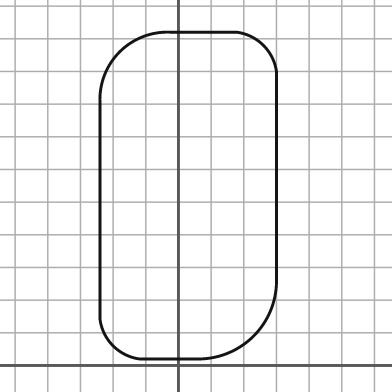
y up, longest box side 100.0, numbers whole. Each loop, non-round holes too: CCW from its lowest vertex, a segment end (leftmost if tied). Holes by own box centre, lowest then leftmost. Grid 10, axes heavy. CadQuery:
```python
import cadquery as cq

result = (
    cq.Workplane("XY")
    .moveTo(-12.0, 2.0)
    .lineTo(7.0, 2.0)
    .threePointArc((23.0, 9.0), (30.0, 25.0))
    .lineTo(30.0, 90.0)
    .threePointArc((26.0, 98.0), (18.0, 102.0))
    .lineTo(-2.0, 102.0)
    .threePointArc((-18.0, 96.0), (-24.0, 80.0))
    .lineTo(-24.0, 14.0)
    .threePointArc((-20.0, 6.0), (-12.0, 2.0))
    .close()
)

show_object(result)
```